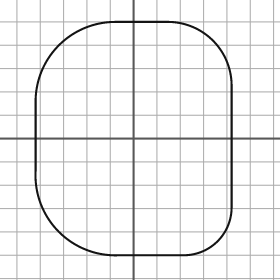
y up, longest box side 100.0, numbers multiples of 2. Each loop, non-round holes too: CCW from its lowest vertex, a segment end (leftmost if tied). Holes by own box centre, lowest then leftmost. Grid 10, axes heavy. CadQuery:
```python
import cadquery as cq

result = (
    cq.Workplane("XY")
    .moveTo(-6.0, -50.0)
    .lineTo(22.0, -50.0)
    .threePointArc((36.0, -44.0), (42.0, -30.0))
    .lineTo(42.0, 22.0)
    .threePointArc((34.0, 42.0), (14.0, 50.0))
    .lineTo(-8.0, 50.0)
    .threePointArc((-32.0, 40.0), (-42.0, 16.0))
    .lineTo(-42.0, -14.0)
    .threePointArc((-32.0, -40.0), (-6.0, -50.0))
    .close()
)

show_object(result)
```